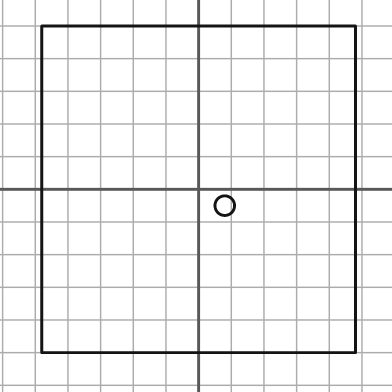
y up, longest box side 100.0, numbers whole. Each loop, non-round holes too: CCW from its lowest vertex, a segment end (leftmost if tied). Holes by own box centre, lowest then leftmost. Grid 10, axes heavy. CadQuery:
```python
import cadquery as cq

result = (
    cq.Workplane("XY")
    .moveTo(-48.0, -50.0)
    .lineTo(48.0, -50.0)
    .lineTo(48.0, 50.0)
    .lineTo(-48.0, 50.0)
    .close()
    .moveTo(8.0, -5.0)
    .circle(3.0)
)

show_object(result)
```